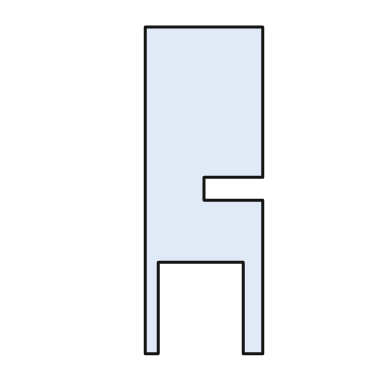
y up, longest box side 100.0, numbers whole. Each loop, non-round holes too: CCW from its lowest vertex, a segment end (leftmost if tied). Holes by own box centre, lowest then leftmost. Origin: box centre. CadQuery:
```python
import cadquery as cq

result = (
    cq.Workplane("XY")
    .moveTo(-18.0, -50.0)
    .lineTo(-14.0, -50.0)
    .lineTo(-14.0, -22.0)
    .lineTo(12.0, -22.0)
    .lineTo(12.0, -50.0)
    .lineTo(18.0, -50.0)
    .lineTo(18.0, -3.0)
    .lineTo(0.0, -3.0)
    .lineTo(0.0, 4.0)
    .lineTo(18.0, 4.0)
    .lineTo(18.0, 50.0)
    .lineTo(-18.0, 50.0)
    .close()
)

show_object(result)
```